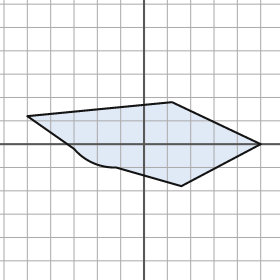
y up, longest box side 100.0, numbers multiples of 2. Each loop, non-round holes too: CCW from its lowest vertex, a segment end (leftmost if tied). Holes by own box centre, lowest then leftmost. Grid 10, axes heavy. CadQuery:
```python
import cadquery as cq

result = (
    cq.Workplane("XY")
    .moveTo(16.0, -18.0)
    .lineTo(50.0, 0.0)
    .lineTo(12.0, 18.0)
    .lineTo(-50.0, 12.0)
    .lineTo(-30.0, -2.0)
    .threePointArc((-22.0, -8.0), (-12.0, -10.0))
    .close()
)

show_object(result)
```